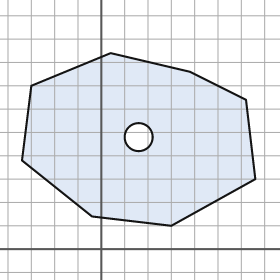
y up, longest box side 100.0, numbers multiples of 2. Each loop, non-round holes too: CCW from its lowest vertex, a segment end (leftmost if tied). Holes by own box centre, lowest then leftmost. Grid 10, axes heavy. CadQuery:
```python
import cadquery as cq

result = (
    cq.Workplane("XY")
    .moveTo(30.0, 10.0)
    .lineTo(66.0, 30.0)
    .lineTo(62.0, 64.0)
    .lineTo(38.0, 76.0)
    .lineTo(4.0, 84.0)
    .lineTo(-30.0, 70.0)
    .lineTo(-34.0, 38.0)
    .lineTo(-4.0, 14.0)
    .close()
    .moveTo(16.0, 48.0)
    .circle(6.0)
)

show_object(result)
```